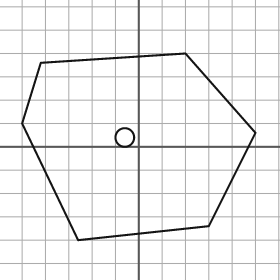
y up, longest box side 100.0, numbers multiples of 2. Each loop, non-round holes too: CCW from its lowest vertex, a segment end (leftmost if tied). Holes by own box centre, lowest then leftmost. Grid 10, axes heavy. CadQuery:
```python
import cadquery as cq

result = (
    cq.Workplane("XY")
    .moveTo(-26.0, -40.0)
    .lineTo(30.0, -34.0)
    .lineTo(50.0, 6.0)
    .lineTo(20.0, 40.0)
    .lineTo(-42.0, 36.0)
    .lineTo(-50.0, 10.0)
    .close()
    .moveTo(-6.0, 4.0)
    .circle(4.0)
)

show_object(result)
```